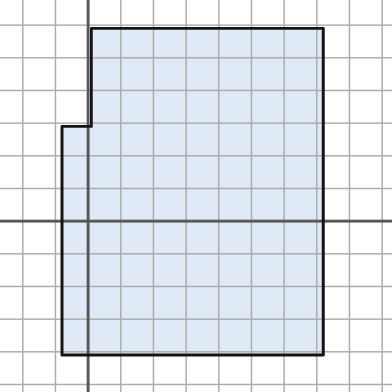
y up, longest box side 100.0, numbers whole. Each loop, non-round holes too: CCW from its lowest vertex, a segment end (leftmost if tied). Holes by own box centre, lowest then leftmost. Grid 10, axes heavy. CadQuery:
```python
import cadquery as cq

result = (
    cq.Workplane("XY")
    .moveTo(-8.0, -41.0)
    .lineTo(72.0, -41.0)
    .lineTo(72.0, 59.0)
    .lineTo(1.0, 59.0)
    .lineTo(1.0, 29.0)
    .lineTo(-8.0, 29.0)
    .close()
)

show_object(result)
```